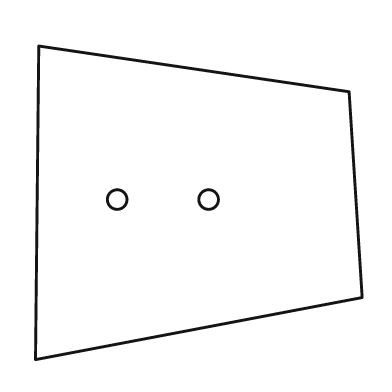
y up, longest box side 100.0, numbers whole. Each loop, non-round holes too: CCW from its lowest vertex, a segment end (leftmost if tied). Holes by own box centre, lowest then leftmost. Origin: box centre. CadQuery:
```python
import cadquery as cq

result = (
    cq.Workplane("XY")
    .moveTo(-50.0, -48.0)
    .lineTo(50.0, -29.0)
    .lineTo(46.0, 34.0)
    .lineTo(-49.0, 48.0)
    .close()
    .moveTo(-25.0, 1.0)
    .circle(3.0)
    .moveTo(3.0, 1.0)
    .circle(3.0)
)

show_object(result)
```